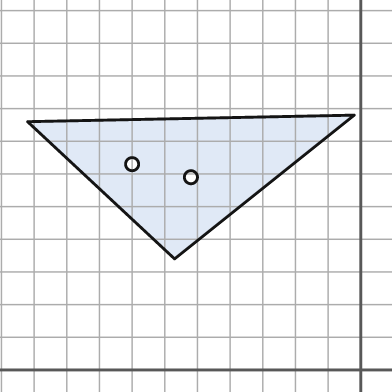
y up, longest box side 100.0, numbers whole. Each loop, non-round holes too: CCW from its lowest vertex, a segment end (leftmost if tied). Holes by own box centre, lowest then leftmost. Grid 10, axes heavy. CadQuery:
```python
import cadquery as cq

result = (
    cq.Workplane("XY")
    .moveTo(-57.0, 34.0)
    .lineTo(-2.0, 78.0)
    .lineTo(-102.0, 76.0)
    .close()
    .moveTo(-52.0, 59.0)
    .circle(2.0)
    .moveTo(-70.0, 63.0)
    .circle(2.0)
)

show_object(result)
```